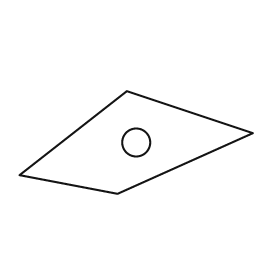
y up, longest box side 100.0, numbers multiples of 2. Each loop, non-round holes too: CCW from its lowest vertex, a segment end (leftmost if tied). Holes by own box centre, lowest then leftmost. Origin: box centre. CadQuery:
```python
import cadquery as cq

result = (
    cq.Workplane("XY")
    .moveTo(-8.0, -22.0)
    .lineTo(50.0, 4.0)
    .lineTo(-4.0, 22.0)
    .lineTo(-50.0, -14.0)
    .close()
    .moveTo(0.0, 0.0)
    .circle(6.0)
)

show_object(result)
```